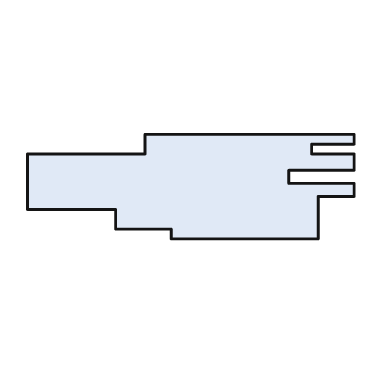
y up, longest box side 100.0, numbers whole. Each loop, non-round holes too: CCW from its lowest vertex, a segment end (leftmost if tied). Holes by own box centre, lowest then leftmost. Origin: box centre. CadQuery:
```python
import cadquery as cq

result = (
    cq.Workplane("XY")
    .moveTo(-6.0, -16.0)
    .lineTo(39.0, -16.0)
    .lineTo(39.0, -3.0)
    .lineTo(50.0, -3.0)
    .lineTo(50.0, 1.0)
    .lineTo(30.0, 1.0)
    .lineTo(30.0, 5.0)
    .lineTo(50.0, 5.0)
    .lineTo(50.0, 10.0)
    .lineTo(37.0, 10.0)
    .lineTo(37.0, 13.0)
    .lineTo(50.0, 13.0)
    .lineTo(50.0, 16.0)
    .lineTo(-14.0, 16.0)
    .lineTo(-14.0, 10.0)
    .lineTo(-50.0, 10.0)
    .lineTo(-50.0, -7.0)
    .lineTo(-23.0, -7.0)
    .lineTo(-23.0, -13.0)
    .lineTo(-6.0, -13.0)
    .close()
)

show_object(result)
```